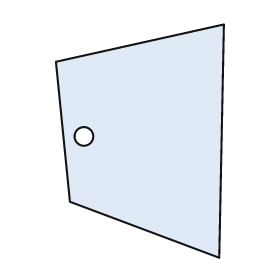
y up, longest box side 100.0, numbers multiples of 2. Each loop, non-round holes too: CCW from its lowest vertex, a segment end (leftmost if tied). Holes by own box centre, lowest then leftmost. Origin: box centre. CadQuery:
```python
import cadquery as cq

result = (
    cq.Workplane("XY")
    .moveTo(34.0, -50.0)
    .lineTo(36.0, 50.0)
    .lineTo(-36.0, 34.0)
    .lineTo(-30.0, -26.0)
    .close()
    .moveTo(-24.0, 2.0)
    .circle(4.0)
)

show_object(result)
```